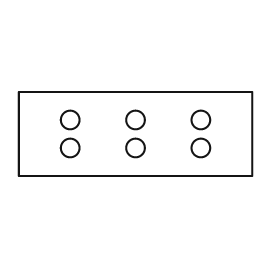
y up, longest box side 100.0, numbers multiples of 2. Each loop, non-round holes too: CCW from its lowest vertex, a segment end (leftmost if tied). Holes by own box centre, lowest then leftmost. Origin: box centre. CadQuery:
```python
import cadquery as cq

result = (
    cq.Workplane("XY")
    .moveTo(-50.0, -18.0)
    .lineTo(50.0, -18.0)
    .lineTo(50.0, 18.0)
    .lineTo(-50.0, 18.0)
    .close()
    .moveTo(-28.0, -6.0)
    .circle(4.0)
    .moveTo(0.0, -6.0)
    .circle(4.0)
    .moveTo(28.0, -6.0)
    .circle(4.0)
    .moveTo(-28.0, 6.0)
    .circle(4.0)
    .moveTo(0.0, 6.0)
    .circle(4.0)
    .moveTo(28.0, 6.0)
    .circle(4.0)
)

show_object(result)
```